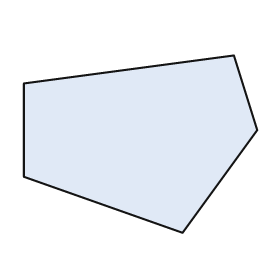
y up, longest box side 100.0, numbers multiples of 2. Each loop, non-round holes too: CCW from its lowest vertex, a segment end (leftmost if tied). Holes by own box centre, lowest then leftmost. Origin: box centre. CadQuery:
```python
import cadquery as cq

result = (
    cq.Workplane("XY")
    .moveTo(18.0, -38.0)
    .lineTo(50.0, 6.0)
    .lineTo(40.0, 38.0)
    .lineTo(-50.0, 26.0)
    .lineTo(-50.0, -14.0)
    .close()
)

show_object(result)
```